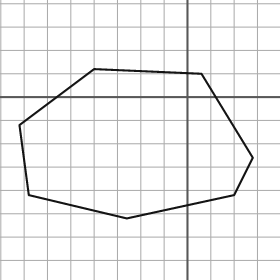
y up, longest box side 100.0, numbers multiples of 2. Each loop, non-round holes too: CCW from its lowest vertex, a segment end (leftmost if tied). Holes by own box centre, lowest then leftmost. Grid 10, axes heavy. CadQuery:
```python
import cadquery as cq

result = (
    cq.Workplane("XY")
    .moveTo(-26.0, -52.0)
    .lineTo(20.0, -42.0)
    .lineTo(28.0, -26.0)
    .lineTo(6.0, 10.0)
    .lineTo(-40.0, 12.0)
    .lineTo(-72.0, -12.0)
    .lineTo(-68.0, -42.0)
    .close()
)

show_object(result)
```